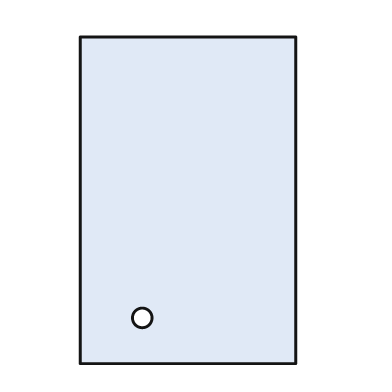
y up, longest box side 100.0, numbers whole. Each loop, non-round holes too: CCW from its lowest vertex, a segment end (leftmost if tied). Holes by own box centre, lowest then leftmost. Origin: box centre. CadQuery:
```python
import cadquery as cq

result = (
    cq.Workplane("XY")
    .moveTo(-33.0, -50.0)
    .lineTo(33.0, -50.0)
    .lineTo(33.0, 50.0)
    .lineTo(-33.0, 50.0)
    .close()
    .moveTo(-14.0, -36.0)
    .circle(3.0)
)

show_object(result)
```